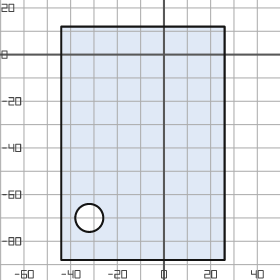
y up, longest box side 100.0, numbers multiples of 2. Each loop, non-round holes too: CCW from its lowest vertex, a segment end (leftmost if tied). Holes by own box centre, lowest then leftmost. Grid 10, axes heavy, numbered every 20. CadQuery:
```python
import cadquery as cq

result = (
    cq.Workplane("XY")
    .moveTo(-44.0, -88.0)
    .lineTo(26.0, -88.0)
    .lineTo(26.0, 12.0)
    .lineTo(-44.0, 12.0)
    .close()
    .moveTo(-32.0, -70.0)
    .circle(6.0)
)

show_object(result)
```